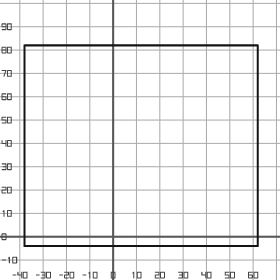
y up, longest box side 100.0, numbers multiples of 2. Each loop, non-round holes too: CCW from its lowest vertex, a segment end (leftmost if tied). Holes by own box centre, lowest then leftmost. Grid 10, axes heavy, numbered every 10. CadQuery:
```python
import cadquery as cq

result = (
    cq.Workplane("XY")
    .moveTo(-38.0, -4.0)
    .lineTo(62.0, -4.0)
    .lineTo(62.0, 82.0)
    .lineTo(-38.0, 82.0)
    .close()
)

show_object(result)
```